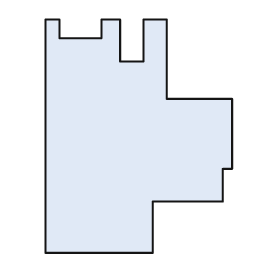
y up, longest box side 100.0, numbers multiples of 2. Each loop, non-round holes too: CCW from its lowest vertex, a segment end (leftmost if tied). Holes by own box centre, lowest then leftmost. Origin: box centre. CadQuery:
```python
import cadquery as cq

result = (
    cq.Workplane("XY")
    .moveTo(-40.0, -50.0)
    .lineTo(6.0, -50.0)
    .lineTo(6.0, -28.0)
    .lineTo(36.0, -28.0)
    .lineTo(36.0, -14.0)
    .lineTo(40.0, -14.0)
    .lineTo(40.0, 16.0)
    .lineTo(12.0, 16.0)
    .lineTo(12.0, 50.0)
    .lineTo(2.0, 50.0)
    .lineTo(2.0, 32.0)
    .lineTo(-8.0, 32.0)
    .lineTo(-8.0, 50.0)
    .lineTo(-16.0, 50.0)
    .lineTo(-16.0, 42.0)
    .lineTo(-34.0, 42.0)
    .lineTo(-34.0, 50.0)
    .lineTo(-40.0, 50.0)
    .close()
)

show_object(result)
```